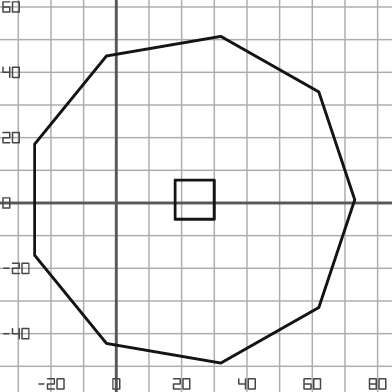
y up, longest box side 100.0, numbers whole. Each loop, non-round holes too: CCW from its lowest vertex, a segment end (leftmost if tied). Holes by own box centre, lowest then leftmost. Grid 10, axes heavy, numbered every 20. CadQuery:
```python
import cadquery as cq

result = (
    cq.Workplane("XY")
    .moveTo(32.0, -49.0)
    .lineTo(62.0, -32.0)
    .lineTo(73.0, 1.0)
    .lineTo(62.0, 34.0)
    .lineTo(32.0, 51.0)
    .lineTo(-3.0, 45.0)
    .lineTo(-25.0, 18.0)
    .lineTo(-25.0, -16.0)
    .lineTo(-3.0, -43.0)
    .close()
    .moveTo(18.0, -5.0)
    .lineTo(30.0, -5.0)
    .lineTo(30.0, 7.0)
    .lineTo(18.0, 7.0)
    .close()
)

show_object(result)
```